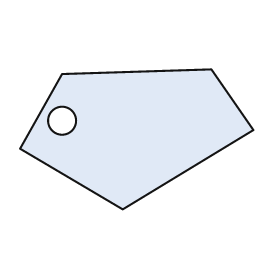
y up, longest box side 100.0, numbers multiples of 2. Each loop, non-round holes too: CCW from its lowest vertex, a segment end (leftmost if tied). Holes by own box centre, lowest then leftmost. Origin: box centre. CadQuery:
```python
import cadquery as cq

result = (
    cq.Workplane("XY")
    .moveTo(-6.0, -30.0)
    .lineTo(50.0, 4.0)
    .lineTo(32.0, 30.0)
    .lineTo(-32.0, 28.0)
    .lineTo(-50.0, -4.0)
    .close()
    .moveTo(-32.0, 8.0)
    .circle(6.0)
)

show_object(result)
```